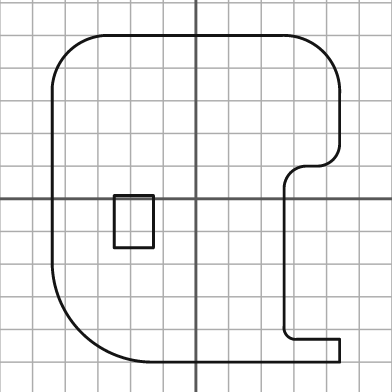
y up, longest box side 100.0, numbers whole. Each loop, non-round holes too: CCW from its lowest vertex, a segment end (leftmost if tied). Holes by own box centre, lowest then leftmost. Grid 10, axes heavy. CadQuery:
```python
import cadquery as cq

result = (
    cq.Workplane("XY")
    .moveTo(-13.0, -50.0)
    .lineTo(44.0, -50.0)
    .lineTo(44.0, -43.0)
    .lineTo(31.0, -43.0)
    .threePointArc((28.0, -42.0), (27.0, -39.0))
    .lineTo(27.0, 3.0)
    .threePointArc((29.0, 8.0), (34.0, 10.0))
    .lineTo(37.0, 10.0)
    .threePointArc((42.0, 12.0), (44.0, 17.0))
    .lineTo(44.0, 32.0)
    .threePointArc((39.0, 45.0), (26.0, 50.0))
    .lineTo(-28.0, 50.0)
    .threePointArc((-39.0, 45.0), (-44.0, 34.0))
    .lineTo(-44.0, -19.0)
    .threePointArc((-35.0, -41.0), (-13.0, -50.0))
    .close()
    .moveTo(-25.0, -15.0)
    .lineTo(-13.0, -15.0)
    .lineTo(-13.0, 1.0)
    .lineTo(-25.0, 1.0)
    .close()
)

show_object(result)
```